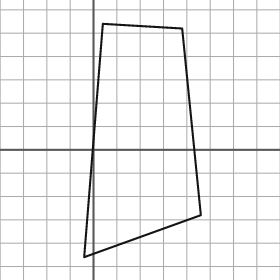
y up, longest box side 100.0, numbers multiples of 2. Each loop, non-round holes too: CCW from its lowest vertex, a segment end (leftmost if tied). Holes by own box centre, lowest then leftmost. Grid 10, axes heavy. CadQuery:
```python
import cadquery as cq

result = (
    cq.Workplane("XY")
    .moveTo(-4.0, -46.0)
    .lineTo(46.0, -28.0)
    .lineTo(38.0, 52.0)
    .lineTo(4.0, 54.0)
    .close()
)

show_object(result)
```